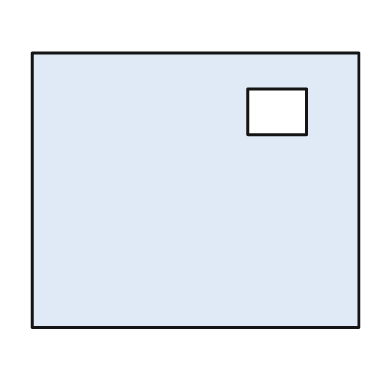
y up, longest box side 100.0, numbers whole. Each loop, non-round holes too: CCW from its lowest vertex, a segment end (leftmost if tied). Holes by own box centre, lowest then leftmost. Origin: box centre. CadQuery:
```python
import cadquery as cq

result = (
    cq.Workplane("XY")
    .moveTo(-50.0, -42.0)
    .lineTo(50.0, -42.0)
    .lineTo(50.0, 42.0)
    .lineTo(-50.0, 42.0)
    .close()
    .moveTo(16.0, 17.0)
    .lineTo(34.0, 17.0)
    .lineTo(34.0, 31.0)
    .lineTo(16.0, 31.0)
    .close()
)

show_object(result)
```